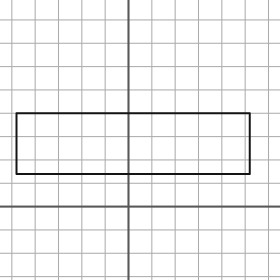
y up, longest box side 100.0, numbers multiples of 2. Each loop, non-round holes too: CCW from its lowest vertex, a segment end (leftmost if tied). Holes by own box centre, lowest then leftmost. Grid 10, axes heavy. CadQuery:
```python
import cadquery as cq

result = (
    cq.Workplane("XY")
    .moveTo(-48.0, 14.0)
    .lineTo(52.0, 14.0)
    .lineTo(52.0, 40.0)
    .lineTo(-48.0, 40.0)
    .close()
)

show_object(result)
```